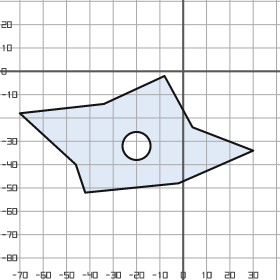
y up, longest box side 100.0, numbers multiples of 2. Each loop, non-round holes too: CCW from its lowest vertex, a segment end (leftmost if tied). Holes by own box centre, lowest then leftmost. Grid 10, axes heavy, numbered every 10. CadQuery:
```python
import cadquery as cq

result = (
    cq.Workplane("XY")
    .moveTo(-42.0, -52.0)
    .lineTo(-2.0, -48.0)
    .lineTo(30.0, -34.0)
    .lineTo(4.0, -24.0)
    .lineTo(-8.0, -2.0)
    .lineTo(-34.0, -14.0)
    .lineTo(-70.0, -18.0)
    .lineTo(-46.0, -40.0)
    .close()
    .moveTo(-20.0, -32.0)
    .circle(6.0)
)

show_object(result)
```